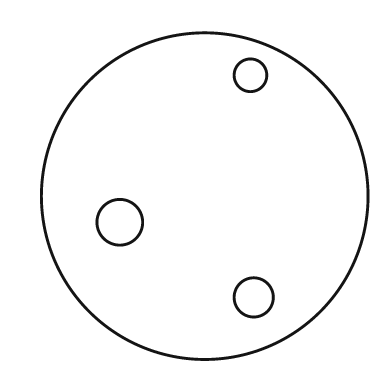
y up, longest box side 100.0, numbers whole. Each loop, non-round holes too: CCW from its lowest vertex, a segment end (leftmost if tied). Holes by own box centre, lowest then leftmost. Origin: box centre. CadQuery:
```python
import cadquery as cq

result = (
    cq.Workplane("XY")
    .moveTo(0.0, 0.0)
    .circle(50.0)
    .moveTo(15.0, -31.0)
    .circle(6.0)
    .moveTo(-26.0, -8.0)
    .circle(7.0)
    .moveTo(14.0, 37.0)
    .circle(5.0)
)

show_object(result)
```